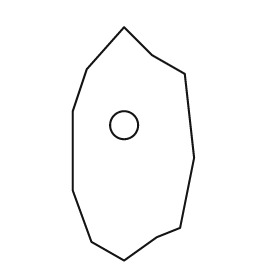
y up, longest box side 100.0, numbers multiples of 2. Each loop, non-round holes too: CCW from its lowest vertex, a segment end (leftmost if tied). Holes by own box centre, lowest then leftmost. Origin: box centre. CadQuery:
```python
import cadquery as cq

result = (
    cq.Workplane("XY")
    .moveTo(-4.0, -50.0)
    .lineTo(10.0, -40.0)
    .lineTo(20.0, -36.0)
    .lineTo(26.0, -6.0)
    .lineTo(22.0, 30.0)
    .lineTo(8.0, 38.0)
    .lineTo(-4.0, 50.0)
    .lineTo(-20.0, 32.0)
    .lineTo(-26.0, 14.0)
    .lineTo(-26.0, -20.0)
    .lineTo(-18.0, -42.0)
    .close()
    .moveTo(-4.0, 8.0)
    .circle(6.0)
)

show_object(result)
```